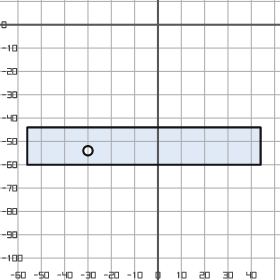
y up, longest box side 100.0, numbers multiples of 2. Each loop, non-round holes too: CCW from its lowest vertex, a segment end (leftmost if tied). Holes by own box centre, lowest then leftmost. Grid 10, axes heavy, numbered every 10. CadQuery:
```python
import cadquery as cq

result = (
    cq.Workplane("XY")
    .moveTo(-56.0, -60.0)
    .lineTo(44.0, -60.0)
    .lineTo(44.0, -44.0)
    .lineTo(-56.0, -44.0)
    .close()
    .moveTo(-30.0, -54.0)
    .circle(2.0)
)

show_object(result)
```